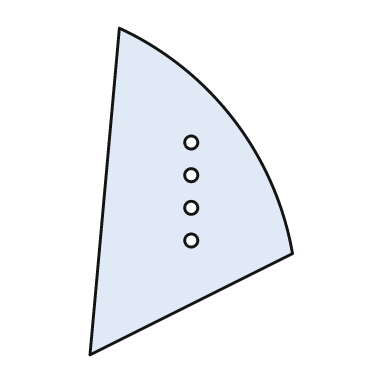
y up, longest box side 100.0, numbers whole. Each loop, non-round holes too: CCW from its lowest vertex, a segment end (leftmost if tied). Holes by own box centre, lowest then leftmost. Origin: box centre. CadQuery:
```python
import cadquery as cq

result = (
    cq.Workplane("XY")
    .moveTo(-31.0, -50.0)
    .lineTo(31.0, -19.0)
    .threePointArc((13.0, 22.0), (-22.0, 50.0))
    .close()
    .moveTo(0.0, -15.0)
    .circle(2.0)
    .moveTo(0.0, -5.0)
    .circle(2.0)
    .moveTo(0.0, 5.0)
    .circle(2.0)
    .moveTo(0.0, 15.0)
    .circle(2.0)
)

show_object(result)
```